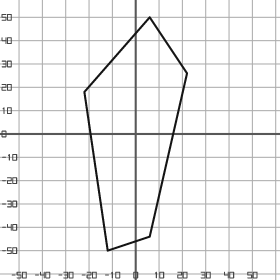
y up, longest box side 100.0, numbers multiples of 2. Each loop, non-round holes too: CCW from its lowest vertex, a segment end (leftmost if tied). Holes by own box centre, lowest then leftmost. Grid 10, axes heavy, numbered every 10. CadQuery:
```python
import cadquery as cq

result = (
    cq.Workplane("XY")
    .moveTo(-12.0, -50.0)
    .lineTo(6.0, -44.0)
    .lineTo(22.0, 26.0)
    .lineTo(6.0, 50.0)
    .lineTo(-22.0, 18.0)
    .close()
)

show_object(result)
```